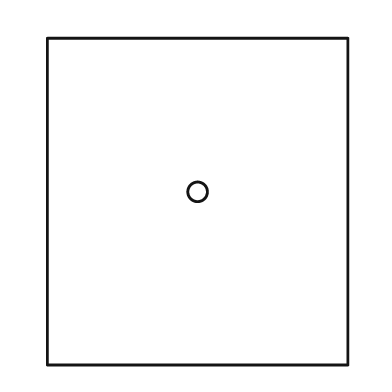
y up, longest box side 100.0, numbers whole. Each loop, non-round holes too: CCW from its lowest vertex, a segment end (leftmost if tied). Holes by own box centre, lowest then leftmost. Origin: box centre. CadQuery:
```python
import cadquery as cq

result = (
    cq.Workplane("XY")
    .moveTo(-46.0, -50.0)
    .lineTo(46.0, -50.0)
    .lineTo(46.0, 50.0)
    .lineTo(-46.0, 50.0)
    .close()
    .moveTo(0.0, 3.0)
    .circle(3.0)
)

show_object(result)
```